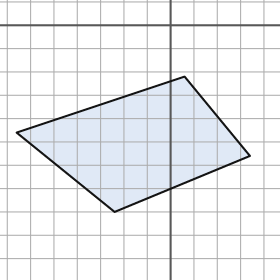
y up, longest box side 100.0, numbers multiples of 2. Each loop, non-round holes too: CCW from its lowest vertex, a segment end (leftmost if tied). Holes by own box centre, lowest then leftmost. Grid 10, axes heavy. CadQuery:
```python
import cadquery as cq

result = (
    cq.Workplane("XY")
    .moveTo(-24.0, -80.0)
    .lineTo(34.0, -56.0)
    .lineTo(6.0, -22.0)
    .lineTo(-66.0, -46.0)
    .close()
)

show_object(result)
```